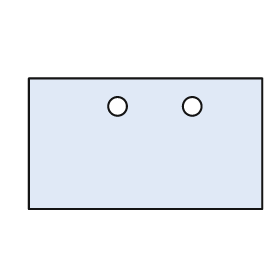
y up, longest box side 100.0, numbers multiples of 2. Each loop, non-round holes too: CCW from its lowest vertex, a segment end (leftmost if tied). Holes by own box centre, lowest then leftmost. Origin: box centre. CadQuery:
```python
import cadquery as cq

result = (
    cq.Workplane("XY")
    .moveTo(-50.0, -28.0)
    .lineTo(50.0, -28.0)
    .lineTo(50.0, 28.0)
    .lineTo(-50.0, 28.0)
    .close()
    .moveTo(-12.0, 16.0)
    .circle(4.0)
    .moveTo(20.0, 16.0)
    .circle(4.0)
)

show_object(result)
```